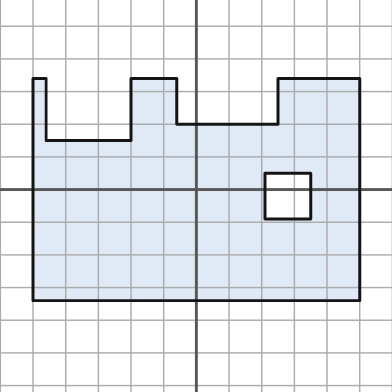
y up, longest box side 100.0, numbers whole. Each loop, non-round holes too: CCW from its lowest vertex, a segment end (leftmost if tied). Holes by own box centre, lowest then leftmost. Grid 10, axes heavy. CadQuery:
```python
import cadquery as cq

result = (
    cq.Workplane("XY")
    .moveTo(-50.0, -34.0)
    .lineTo(50.0, -34.0)
    .lineTo(50.0, 34.0)
    .lineTo(25.0, 34.0)
    .lineTo(25.0, 20.0)
    .lineTo(-6.0, 20.0)
    .lineTo(-6.0, 34.0)
    .lineTo(-20.0, 34.0)
    .lineTo(-20.0, 15.0)
    .lineTo(-46.0, 15.0)
    .lineTo(-46.0, 34.0)
    .lineTo(-50.0, 34.0)
    .close()
    .moveTo(21.0, -9.0)
    .lineTo(35.0, -9.0)
    .lineTo(35.0, 5.0)
    .lineTo(21.0, 5.0)
    .close()
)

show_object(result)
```